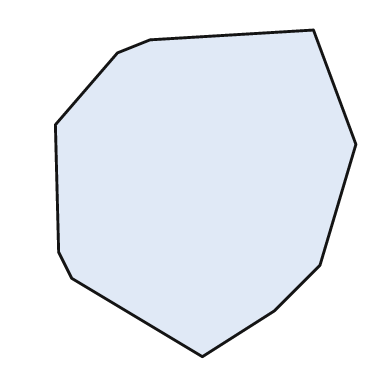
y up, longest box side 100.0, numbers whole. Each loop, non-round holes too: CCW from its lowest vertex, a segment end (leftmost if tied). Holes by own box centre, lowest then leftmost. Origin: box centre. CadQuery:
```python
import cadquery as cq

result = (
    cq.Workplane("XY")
    .moveTo(-1.0, -50.0)
    .lineTo(21.0, -36.0)
    .lineTo(35.0, -22.0)
    .lineTo(46.0, 15.0)
    .lineTo(33.0, 50.0)
    .lineTo(-17.0, 47.0)
    .lineTo(-27.0, 43.0)
    .lineTo(-46.0, 21.0)
    .lineTo(-45.0, -18.0)
    .lineTo(-41.0, -26.0)
    .close()
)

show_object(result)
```